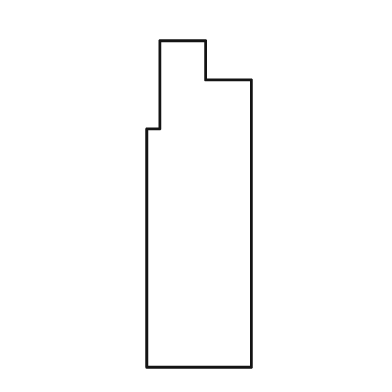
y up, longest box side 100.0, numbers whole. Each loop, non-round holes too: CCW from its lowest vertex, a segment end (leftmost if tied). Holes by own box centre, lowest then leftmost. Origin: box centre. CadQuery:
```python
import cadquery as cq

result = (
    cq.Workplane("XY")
    .moveTo(-16.0, -50.0)
    .lineTo(16.0, -50.0)
    .lineTo(16.0, 38.0)
    .lineTo(2.0, 38.0)
    .lineTo(2.0, 50.0)
    .lineTo(-12.0, 50.0)
    .lineTo(-12.0, 23.0)
    .lineTo(-16.0, 23.0)
    .close()
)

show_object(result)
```